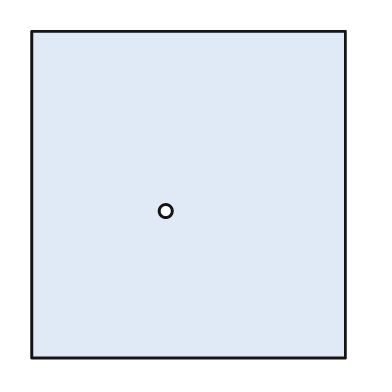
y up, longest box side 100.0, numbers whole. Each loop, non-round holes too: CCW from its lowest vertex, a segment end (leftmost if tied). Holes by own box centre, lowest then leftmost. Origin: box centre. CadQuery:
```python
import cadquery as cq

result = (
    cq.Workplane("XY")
    .moveTo(-48.0, -50.0)
    .lineTo(48.0, -50.0)
    .lineTo(48.0, 50.0)
    .lineTo(-48.0, 50.0)
    .close()
    .moveTo(-7.0, -5.0)
    .circle(2.0)
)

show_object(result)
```